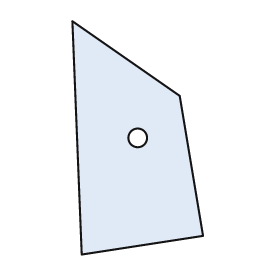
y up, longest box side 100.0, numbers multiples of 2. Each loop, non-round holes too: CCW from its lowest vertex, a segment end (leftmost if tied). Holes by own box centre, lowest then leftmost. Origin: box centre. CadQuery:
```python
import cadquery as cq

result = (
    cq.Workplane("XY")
    .moveTo(-24.0, -50.0)
    .lineTo(28.0, -42.0)
    .lineTo(18.0, 18.0)
    .lineTo(-28.0, 50.0)
    .close()
    .moveTo(0.0, 0.0)
    .circle(4.0)
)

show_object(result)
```